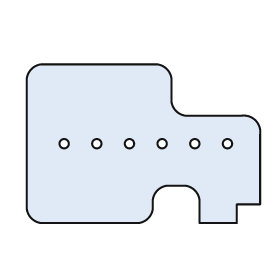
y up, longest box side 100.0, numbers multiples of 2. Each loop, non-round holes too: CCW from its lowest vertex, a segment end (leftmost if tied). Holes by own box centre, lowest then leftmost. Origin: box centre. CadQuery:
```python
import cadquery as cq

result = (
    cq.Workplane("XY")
    .moveTo(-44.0, -34.0)
    .lineTo(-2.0, -34.0)
    .threePointArc((2.0, -32.0), (4.0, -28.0))
    .lineTo(4.0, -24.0)
    .threePointArc((6.0, -20.0), (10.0, -18.0))
    .lineTo(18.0, -18.0)
    .threePointArc((22.0, -20.0), (24.0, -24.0))
    .lineTo(24.0, -34.0)
    .lineTo(40.0, -34.0)
    .lineTo(40.0, -26.0)
    .lineTo(50.0, -26.0)
    .lineTo(50.0, 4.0)
    .threePointArc((48.0, 10.0), (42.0, 12.0))
    .lineTo(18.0, 12.0)
    .threePointArc((14.0, 14.0), (12.0, 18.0))
    .lineTo(12.0, 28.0)
    .threePointArc((10.0, 32.0), (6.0, 34.0))
    .lineTo(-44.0, 34.0)
    .threePointArc((-48.0, 32.0), (-50.0, 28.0))
    .lineTo(-50.0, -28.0)
    .threePointArc((-48.0, -32.0), (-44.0, -34.0))
    .close()
    .moveTo(-34.0, 0.0)
    .circle(2.0)
    .moveTo(-20.0, 0.0)
    .circle(2.0)
    .moveTo(-6.0, 0.0)
    .circle(2.0)
    .moveTo(8.0, 0.0)
    .circle(2.0)
    .moveTo(22.0, 0.0)
    .circle(2.0)
    .moveTo(36.0, 0.0)
    .circle(2.0)
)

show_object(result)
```